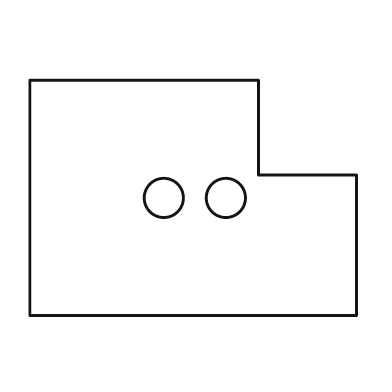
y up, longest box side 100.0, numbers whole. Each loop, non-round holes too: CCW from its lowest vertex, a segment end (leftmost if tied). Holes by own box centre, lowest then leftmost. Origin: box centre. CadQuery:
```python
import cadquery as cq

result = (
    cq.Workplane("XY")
    .moveTo(-50.0, -36.0)
    .lineTo(50.0, -36.0)
    .lineTo(50.0, 7.0)
    .lineTo(20.0, 7.0)
    .lineTo(20.0, 36.0)
    .lineTo(-50.0, 36.0)
    .close()
    .moveTo(-9.0, 0.0)
    .circle(6.0)
    .moveTo(10.0, 0.0)
    .circle(6.0)
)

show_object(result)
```